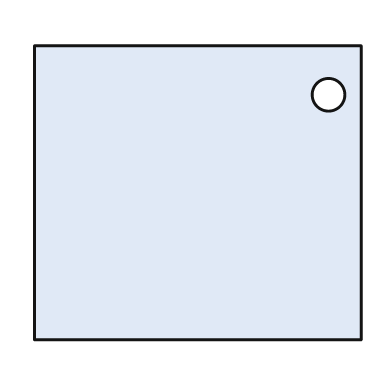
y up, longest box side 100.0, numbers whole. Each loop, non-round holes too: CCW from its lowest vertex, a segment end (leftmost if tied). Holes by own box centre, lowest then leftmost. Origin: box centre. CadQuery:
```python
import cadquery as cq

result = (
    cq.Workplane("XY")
    .moveTo(-50.0, -45.0)
    .lineTo(50.0, -45.0)
    .lineTo(50.0, 45.0)
    .lineTo(-50.0, 45.0)
    .close()
    .moveTo(40.0, 30.0)
    .circle(5.0)
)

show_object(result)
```